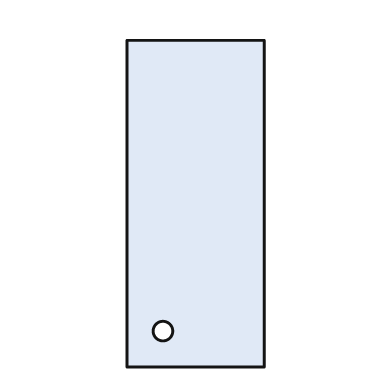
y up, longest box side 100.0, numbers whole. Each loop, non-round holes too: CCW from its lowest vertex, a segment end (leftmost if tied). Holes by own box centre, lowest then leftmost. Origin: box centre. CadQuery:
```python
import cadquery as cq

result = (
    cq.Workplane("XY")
    .moveTo(-21.0, -50.0)
    .lineTo(21.0, -50.0)
    .lineTo(21.0, 50.0)
    .lineTo(-21.0, 50.0)
    .close()
    .moveTo(-10.0, -39.0)
    .circle(3.0)
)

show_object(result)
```